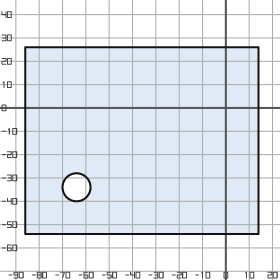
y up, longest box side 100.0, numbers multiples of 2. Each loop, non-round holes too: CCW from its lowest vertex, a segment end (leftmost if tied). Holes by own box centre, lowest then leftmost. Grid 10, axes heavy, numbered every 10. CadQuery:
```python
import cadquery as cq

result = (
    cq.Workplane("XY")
    .moveTo(-86.0, -54.0)
    .lineTo(14.0, -54.0)
    .lineTo(14.0, 26.0)
    .lineTo(-86.0, 26.0)
    .close()
    .moveTo(-64.0, -34.0)
    .circle(6.0)
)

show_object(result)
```